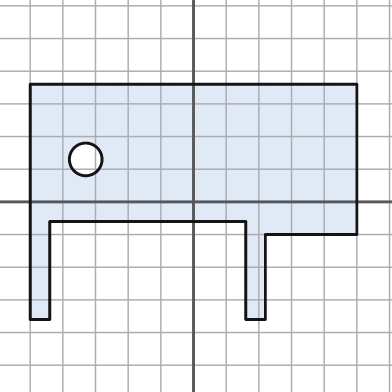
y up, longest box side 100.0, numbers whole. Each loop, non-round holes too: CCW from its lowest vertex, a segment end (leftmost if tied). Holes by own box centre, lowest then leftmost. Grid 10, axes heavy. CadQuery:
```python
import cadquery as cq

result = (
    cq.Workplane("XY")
    .moveTo(-50.0, -36.0)
    .lineTo(-44.0, -36.0)
    .lineTo(-44.0, -6.0)
    .lineTo(16.0, -6.0)
    .lineTo(16.0, -36.0)
    .lineTo(22.0, -36.0)
    .lineTo(22.0, -10.0)
    .lineTo(50.0, -10.0)
    .lineTo(50.0, 36.0)
    .lineTo(-50.0, 36.0)
    .close()
    .moveTo(-33.0, 13.0)
    .circle(5.0)
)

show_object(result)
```